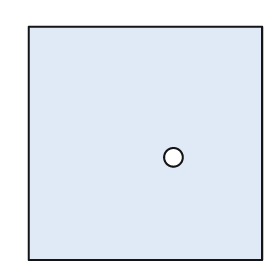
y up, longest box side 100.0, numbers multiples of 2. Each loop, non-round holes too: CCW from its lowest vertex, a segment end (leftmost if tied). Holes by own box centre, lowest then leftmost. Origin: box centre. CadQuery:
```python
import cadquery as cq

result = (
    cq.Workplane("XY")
    .moveTo(-50.0, -50.0)
    .lineTo(50.0, -50.0)
    .lineTo(50.0, 50.0)
    .lineTo(-50.0, 50.0)
    .close()
    .moveTo(12.0, -6.0)
    .circle(4.0)
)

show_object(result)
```